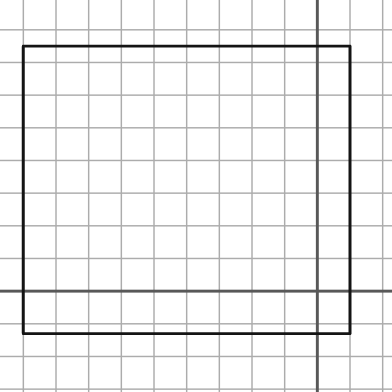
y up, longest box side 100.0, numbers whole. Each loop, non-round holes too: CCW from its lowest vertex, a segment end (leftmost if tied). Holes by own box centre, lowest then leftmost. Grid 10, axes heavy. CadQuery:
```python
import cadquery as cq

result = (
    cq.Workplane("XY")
    .moveTo(-90.0, -13.0)
    .lineTo(10.0, -13.0)
    .lineTo(10.0, 75.0)
    .lineTo(-90.0, 75.0)
    .close()
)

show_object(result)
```